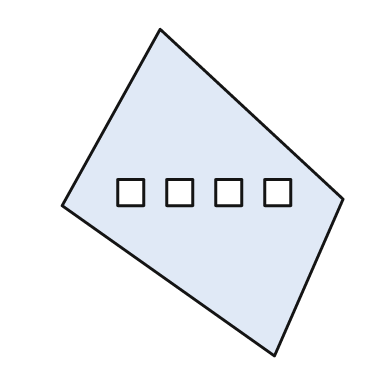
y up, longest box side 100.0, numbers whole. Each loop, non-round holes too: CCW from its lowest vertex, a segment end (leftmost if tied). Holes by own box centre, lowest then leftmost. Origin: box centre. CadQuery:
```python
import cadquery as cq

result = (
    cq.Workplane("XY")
    .moveTo(22.0, -50.0)
    .lineTo(43.0, -2.0)
    .lineTo(-13.0, 50.0)
    .lineTo(-43.0, -4.0)
    .close()
    .moveTo(-26.0, -4.0)
    .lineTo(-18.0, -4.0)
    .lineTo(-18.0, 4.0)
    .lineTo(-26.0, 4.0)
    .close()
    .moveTo(-11.0, -4.0)
    .lineTo(-3.0, -4.0)
    .lineTo(-3.0, 4.0)
    .lineTo(-11.0, 4.0)
    .close()
    .moveTo(4.0, -4.0)
    .lineTo(12.0, -4.0)
    .lineTo(12.0, 4.0)
    .lineTo(4.0, 4.0)
    .close()
    .moveTo(19.0, -4.0)
    .lineTo(27.0, -4.0)
    .lineTo(27.0, 4.0)
    .lineTo(19.0, 4.0)
    .close()
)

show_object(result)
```